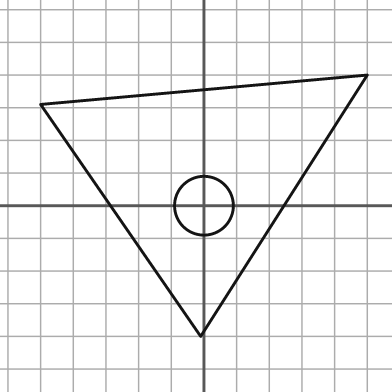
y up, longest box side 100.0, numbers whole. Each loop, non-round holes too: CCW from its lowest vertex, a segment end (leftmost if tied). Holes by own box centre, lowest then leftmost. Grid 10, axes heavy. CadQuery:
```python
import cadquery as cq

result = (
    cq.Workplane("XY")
    .moveTo(-1.0, -40.0)
    .lineTo(50.0, 40.0)
    .lineTo(-50.0, 31.0)
    .close()
    .moveTo(0.0, 0.0)
    .circle(9.0)
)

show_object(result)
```